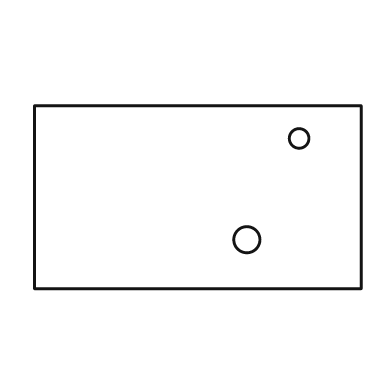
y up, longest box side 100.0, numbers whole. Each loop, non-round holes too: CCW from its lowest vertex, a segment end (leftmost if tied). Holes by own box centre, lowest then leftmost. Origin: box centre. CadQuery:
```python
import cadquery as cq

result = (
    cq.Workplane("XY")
    .moveTo(-50.0, -28.0)
    .lineTo(50.0, -28.0)
    .lineTo(50.0, 28.0)
    .lineTo(-50.0, 28.0)
    .close()
    .moveTo(15.0, -13.0)
    .circle(4.0)
    .moveTo(31.0, 18.0)
    .circle(3.0)
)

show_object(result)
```